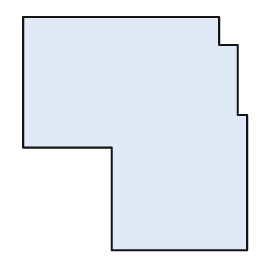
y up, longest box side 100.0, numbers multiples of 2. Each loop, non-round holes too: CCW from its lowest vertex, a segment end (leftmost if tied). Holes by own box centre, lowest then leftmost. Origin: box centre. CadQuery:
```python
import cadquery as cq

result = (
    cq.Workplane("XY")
    .moveTo(-10.0, -50.0)
    .lineTo(48.0, -50.0)
    .lineTo(48.0, 8.0)
    .lineTo(44.0, 8.0)
    .lineTo(44.0, 38.0)
    .lineTo(36.0, 38.0)
    .lineTo(36.0, 50.0)
    .lineTo(-48.0, 50.0)
    .lineTo(-48.0, -6.0)
    .lineTo(-10.0, -6.0)
    .close()
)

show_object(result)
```